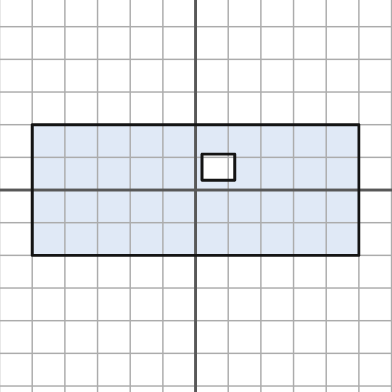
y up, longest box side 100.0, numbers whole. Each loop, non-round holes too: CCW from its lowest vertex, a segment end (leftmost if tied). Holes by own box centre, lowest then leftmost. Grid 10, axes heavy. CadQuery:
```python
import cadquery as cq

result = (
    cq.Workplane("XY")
    .moveTo(-50.0, -20.0)
    .lineTo(50.0, -20.0)
    .lineTo(50.0, 20.0)
    .lineTo(-50.0, 20.0)
    .close()
    .moveTo(2.0, 3.0)
    .lineTo(12.0, 3.0)
    .lineTo(12.0, 11.0)
    .lineTo(2.0, 11.0)
    .close()
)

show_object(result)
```